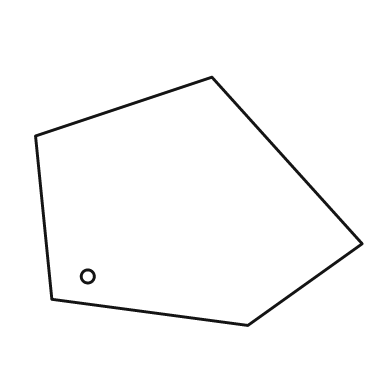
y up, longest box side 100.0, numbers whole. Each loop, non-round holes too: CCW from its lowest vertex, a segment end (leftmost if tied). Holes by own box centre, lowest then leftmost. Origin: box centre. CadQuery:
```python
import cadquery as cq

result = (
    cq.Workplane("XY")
    .moveTo(15.0, -38.0)
    .lineTo(50.0, -13.0)
    .lineTo(4.0, 38.0)
    .lineTo(-50.0, 20.0)
    .lineTo(-45.0, -30.0)
    .close()
    .moveTo(-34.0, -23.0)
    .circle(2.0)
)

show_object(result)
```